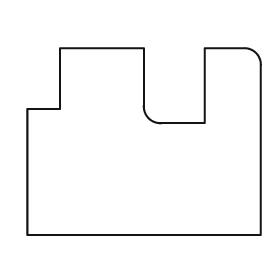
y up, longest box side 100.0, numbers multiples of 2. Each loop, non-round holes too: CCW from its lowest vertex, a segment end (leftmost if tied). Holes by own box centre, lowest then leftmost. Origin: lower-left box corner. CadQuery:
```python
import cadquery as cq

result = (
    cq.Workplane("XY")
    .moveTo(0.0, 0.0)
    .lineTo(100.0, 0.0)
    .lineTo(100.0, 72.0)
    .threePointArc((98.0, 78.0), (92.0, 80.0))
    .lineTo(76.0, 80.0)
    .lineTo(76.0, 48.0)
    .lineTo(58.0, 48.0)
    .threePointArc((52.0, 50.0), (50.0, 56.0))
    .lineTo(50.0, 80.0)
    .lineTo(14.0, 80.0)
    .lineTo(14.0, 54.0)
    .lineTo(0.0, 54.0)
    .close()
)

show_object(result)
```